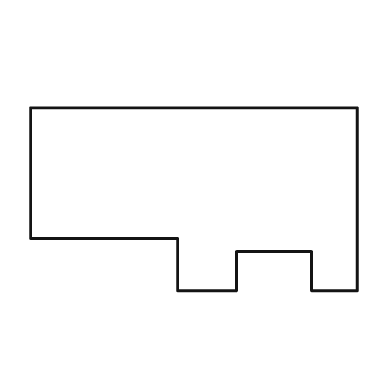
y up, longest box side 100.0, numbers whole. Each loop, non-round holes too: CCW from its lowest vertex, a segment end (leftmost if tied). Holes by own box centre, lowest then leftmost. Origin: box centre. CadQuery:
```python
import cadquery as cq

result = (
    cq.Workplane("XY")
    .moveTo(-5.0, -28.0)
    .lineTo(13.0, -28.0)
    .lineTo(13.0, -16.0)
    .lineTo(36.0, -16.0)
    .lineTo(36.0, -28.0)
    .lineTo(50.0, -28.0)
    .lineTo(50.0, 28.0)
    .lineTo(-50.0, 28.0)
    .lineTo(-50.0, -12.0)
    .lineTo(-5.0, -12.0)
    .close()
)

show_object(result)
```